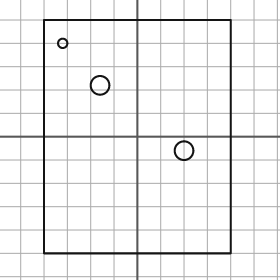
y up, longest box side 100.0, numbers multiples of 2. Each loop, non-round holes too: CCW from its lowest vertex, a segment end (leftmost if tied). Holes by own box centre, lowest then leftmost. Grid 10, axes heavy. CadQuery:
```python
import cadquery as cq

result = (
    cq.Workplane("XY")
    .moveTo(-40.0, -50.0)
    .lineTo(40.0, -50.0)
    .lineTo(40.0, 50.0)
    .lineTo(-40.0, 50.0)
    .close()
    .moveTo(20.0, -6.0)
    .circle(4.0)
    .moveTo(-16.0, 22.0)
    .circle(4.0)
    .moveTo(-32.0, 40.0)
    .circle(2.0)
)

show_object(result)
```